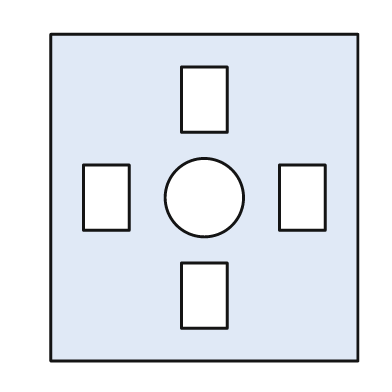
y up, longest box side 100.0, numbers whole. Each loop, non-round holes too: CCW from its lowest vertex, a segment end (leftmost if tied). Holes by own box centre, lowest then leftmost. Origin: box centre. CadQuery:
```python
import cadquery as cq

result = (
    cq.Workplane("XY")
    .moveTo(-47.0, -50.0)
    .lineTo(47.0, -50.0)
    .lineTo(47.0, 50.0)
    .lineTo(-47.0, 50.0)
    .close()
    .moveTo(-7.0, -40.0)
    .lineTo(7.0, -40.0)
    .lineTo(7.0, -20.0)
    .lineTo(-7.0, -20.0)
    .close()
    .moveTo(-37.0, -10.0)
    .lineTo(-23.0, -10.0)
    .lineTo(-23.0, 10.0)
    .lineTo(-37.0, 10.0)
    .close()
    .moveTo(0.0, 0.0)
    .circle(12.0)
    .moveTo(23.0, -10.0)
    .lineTo(37.0, -10.0)
    .lineTo(37.0, 10.0)
    .lineTo(23.0, 10.0)
    .close()
    .moveTo(-7.0, 20.0)
    .lineTo(7.0, 20.0)
    .lineTo(7.0, 40.0)
    .lineTo(-7.0, 40.0)
    .close()
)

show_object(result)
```